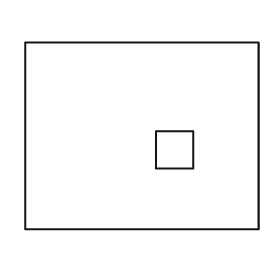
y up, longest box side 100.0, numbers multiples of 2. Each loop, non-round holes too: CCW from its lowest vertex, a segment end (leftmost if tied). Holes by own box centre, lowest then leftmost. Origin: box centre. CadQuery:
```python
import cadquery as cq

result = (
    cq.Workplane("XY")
    .moveTo(-50.0, -40.0)
    .lineTo(50.0, -40.0)
    .lineTo(50.0, 40.0)
    .lineTo(-50.0, 40.0)
    .close()
    .moveTo(6.0, -14.0)
    .lineTo(22.0, -14.0)
    .lineTo(22.0, 2.0)
    .lineTo(6.0, 2.0)
    .close()
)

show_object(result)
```